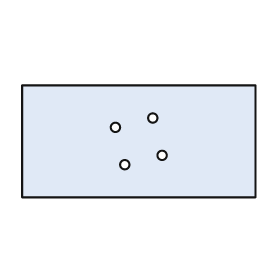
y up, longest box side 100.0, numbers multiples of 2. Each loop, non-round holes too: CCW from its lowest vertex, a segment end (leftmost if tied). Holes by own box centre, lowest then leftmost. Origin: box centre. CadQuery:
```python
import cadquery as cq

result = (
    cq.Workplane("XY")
    .moveTo(-50.0, -24.0)
    .lineTo(50.0, -24.0)
    .lineTo(50.0, 24.0)
    .lineTo(-50.0, 24.0)
    .close()
    .moveTo(-6.0, -10.0)
    .circle(2.0)
    .moveTo(10.0, -6.0)
    .circle(2.0)
    .moveTo(-10.0, 6.0)
    .circle(2.0)
    .moveTo(6.0, 10.0)
    .circle(2.0)
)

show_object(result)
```